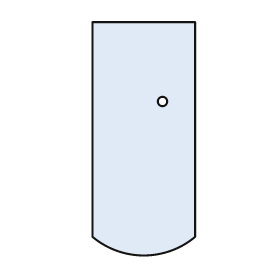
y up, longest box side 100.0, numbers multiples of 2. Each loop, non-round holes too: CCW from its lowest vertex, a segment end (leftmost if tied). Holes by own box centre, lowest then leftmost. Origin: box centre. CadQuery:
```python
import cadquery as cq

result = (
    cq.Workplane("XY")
    .moveTo(-22.0, -42.0)
    .threePointArc((0.0, -50.0), (22.0, -42.0))
    .lineTo(22.0, 50.0)
    .lineTo(-22.0, 50.0)
    .close()
    .moveTo(8.0, 16.0)
    .circle(2.0)
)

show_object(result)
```